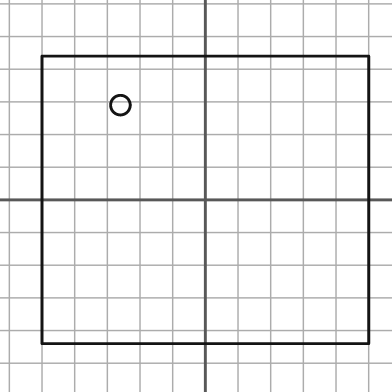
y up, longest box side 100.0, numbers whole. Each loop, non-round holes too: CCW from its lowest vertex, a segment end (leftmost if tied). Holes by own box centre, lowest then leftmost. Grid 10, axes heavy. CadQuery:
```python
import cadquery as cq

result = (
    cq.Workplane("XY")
    .moveTo(-50.0, -44.0)
    .lineTo(50.0, -44.0)
    .lineTo(50.0, 44.0)
    .lineTo(-50.0, 44.0)
    .close()
    .moveTo(-26.0, 29.0)
    .circle(3.0)
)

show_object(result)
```